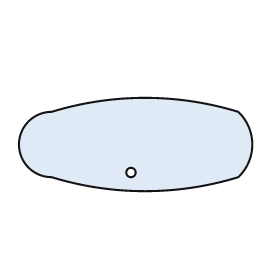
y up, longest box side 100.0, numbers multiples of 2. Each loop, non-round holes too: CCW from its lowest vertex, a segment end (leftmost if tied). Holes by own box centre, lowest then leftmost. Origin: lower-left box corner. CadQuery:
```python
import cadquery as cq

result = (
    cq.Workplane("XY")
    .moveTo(14.0, 6.0)
    .threePointArc((54.0, 0.0), (94.0, 6.0))
    .threePointArc((100.0, 20.0), (94.0, 34.0))
    .threePointArc((54.0, 40.0), (14.0, 34.0))
    .threePointArc((0.0, 20.0), (14.0, 6.0))
    .close()
    .moveTo(48.0, 8.0)
    .circle(2.0)
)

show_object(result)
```